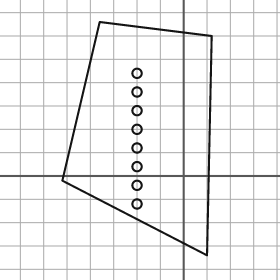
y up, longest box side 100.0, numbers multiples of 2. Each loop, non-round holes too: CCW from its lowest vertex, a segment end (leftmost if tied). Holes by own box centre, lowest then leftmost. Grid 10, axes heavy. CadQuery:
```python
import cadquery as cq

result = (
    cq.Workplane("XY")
    .moveTo(10.0, -34.0)
    .lineTo(12.0, 60.0)
    .lineTo(-36.0, 66.0)
    .lineTo(-52.0, -2.0)
    .close()
    .moveTo(-20.0, -12.0)
    .circle(2.0)
    .moveTo(-20.0, -4.0)
    .circle(2.0)
    .moveTo(-20.0, 4.0)
    .circle(2.0)
    .moveTo(-20.0, 12.0)
    .circle(2.0)
    .moveTo(-20.0, 20.0)
    .circle(2.0)
    .moveTo(-20.0, 28.0)
    .circle(2.0)
    .moveTo(-20.0, 36.0)
    .circle(2.0)
    .moveTo(-20.0, 44.0)
    .circle(2.0)
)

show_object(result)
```